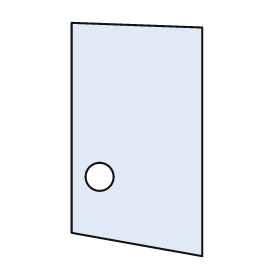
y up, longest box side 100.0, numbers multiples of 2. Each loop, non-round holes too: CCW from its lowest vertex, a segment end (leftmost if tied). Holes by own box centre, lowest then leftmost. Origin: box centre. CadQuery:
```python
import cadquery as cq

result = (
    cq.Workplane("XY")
    .moveTo(28.0, -50.0)
    .lineTo(28.0, 48.0)
    .lineTo(-28.0, 50.0)
    .lineTo(-28.0, -40.0)
    .close()
    .moveTo(-16.0, -16.0)
    .circle(6.0)
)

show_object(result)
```